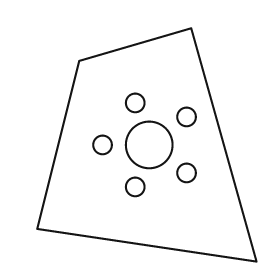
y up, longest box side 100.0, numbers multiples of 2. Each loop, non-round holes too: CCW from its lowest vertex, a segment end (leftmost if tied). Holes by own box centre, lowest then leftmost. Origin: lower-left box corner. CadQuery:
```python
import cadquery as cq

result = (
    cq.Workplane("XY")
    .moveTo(94.0, 0.0)
    .lineTo(66.0, 100.0)
    .lineTo(18.0, 86.0)
    .lineTo(0.0, 14.0)
    .close()
    .moveTo(42.0, 32.0)
    .circle(4.0)
    .moveTo(64.0, 38.0)
    .circle(4.0)
    .moveTo(28.0, 50.0)
    .circle(4.0)
    .moveTo(48.0, 50.0)
    .circle(10.0)
    .moveTo(64.0, 62.0)
    .circle(4.0)
    .moveTo(42.0, 68.0)
    .circle(4.0)
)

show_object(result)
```